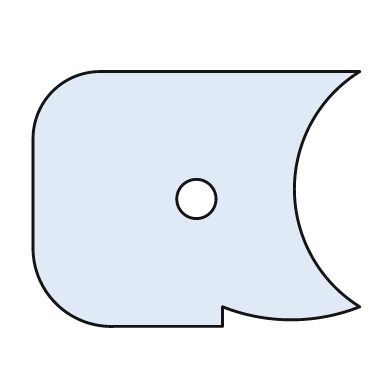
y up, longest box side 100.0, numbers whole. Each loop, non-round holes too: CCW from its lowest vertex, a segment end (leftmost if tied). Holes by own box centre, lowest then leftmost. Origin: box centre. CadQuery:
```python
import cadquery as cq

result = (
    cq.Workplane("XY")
    .moveTo(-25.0, -39.0)
    .lineTo(8.0, -39.0)
    .lineTo(8.0, -33.0)
    .threePointArc((29.0, -37.0), (50.0, -33.0))
    .threePointArc((30.0, 3.0), (50.0, 39.0))
    .lineTo(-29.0, 39.0)
    .threePointArc((-44.0, 33.0), (-50.0, 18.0))
    .lineTo(-50.0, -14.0)
    .threePointArc((-43.0, -32.0), (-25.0, -39.0))
    .close()
    .moveTo(0.0, 0.0)
    .circle(6.0)
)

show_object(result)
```